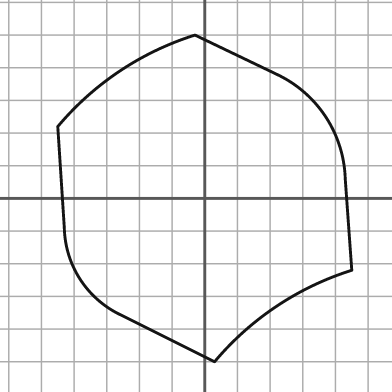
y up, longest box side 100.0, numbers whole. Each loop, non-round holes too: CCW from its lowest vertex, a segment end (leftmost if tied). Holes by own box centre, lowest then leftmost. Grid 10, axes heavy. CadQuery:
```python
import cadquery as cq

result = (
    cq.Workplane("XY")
    .moveTo(3.0, -50.0)
    .threePointArc((22.0, -33.0), (45.0, -22.0))
    .lineTo(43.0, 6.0)
    .threePointArc((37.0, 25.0), (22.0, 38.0))
    .lineTo(-3.0, 50.0)
    .threePointArc((-26.0, 39.0), (-45.0, 22.0))
    .lineTo(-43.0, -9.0)
    .threePointArc((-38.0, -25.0), (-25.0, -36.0))
    .close()
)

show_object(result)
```